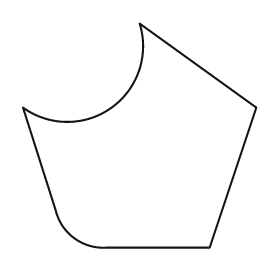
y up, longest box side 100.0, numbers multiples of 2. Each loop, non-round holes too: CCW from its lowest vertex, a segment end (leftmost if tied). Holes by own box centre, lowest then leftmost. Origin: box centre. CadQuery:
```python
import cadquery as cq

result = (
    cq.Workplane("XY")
    .moveTo(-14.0, -48.0)
    .lineTo(30.0, -48.0)
    .lineTo(50.0, 12.0)
    .lineTo(0.0, 48.0)
    .threePointArc((-12.0, 12.0), (-50.0, 12.0))
    .lineTo(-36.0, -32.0)
    .threePointArc((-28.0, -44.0), (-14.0, -48.0))
    .close()
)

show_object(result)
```